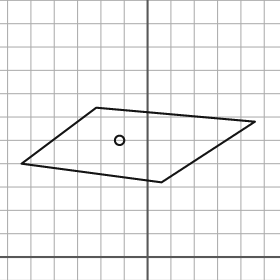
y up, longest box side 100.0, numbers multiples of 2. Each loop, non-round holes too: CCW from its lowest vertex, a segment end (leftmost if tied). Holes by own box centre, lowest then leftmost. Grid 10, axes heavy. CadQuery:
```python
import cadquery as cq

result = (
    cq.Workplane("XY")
    .moveTo(6.0, 32.0)
    .lineTo(46.0, 58.0)
    .lineTo(-22.0, 64.0)
    .lineTo(-54.0, 40.0)
    .close()
    .moveTo(-12.0, 50.0)
    .circle(2.0)
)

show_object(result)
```